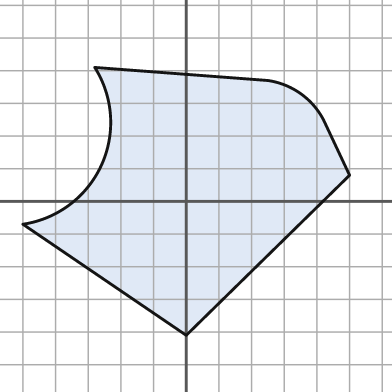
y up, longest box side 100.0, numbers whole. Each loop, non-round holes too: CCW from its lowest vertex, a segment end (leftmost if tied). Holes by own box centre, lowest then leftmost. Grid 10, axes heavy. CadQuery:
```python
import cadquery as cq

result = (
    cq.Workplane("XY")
    .moveTo(0.0, -41.0)
    .lineTo(50.0, 8.0)
    .lineTo(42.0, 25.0)
    .threePointArc((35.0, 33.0), (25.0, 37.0))
    .lineTo(-28.0, 41.0)
    .threePointArc((-26.0, 11.0), (-50.0, -7.0))
    .close()
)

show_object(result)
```